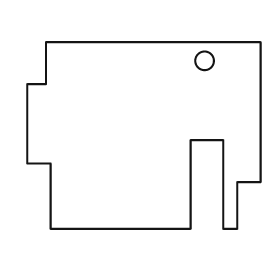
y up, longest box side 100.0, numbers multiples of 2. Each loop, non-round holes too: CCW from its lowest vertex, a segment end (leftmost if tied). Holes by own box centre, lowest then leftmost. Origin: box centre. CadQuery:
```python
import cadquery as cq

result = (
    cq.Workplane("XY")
    .moveTo(-40.0, -40.0)
    .lineTo(20.0, -40.0)
    .lineTo(20.0, -2.0)
    .lineTo(34.0, -2.0)
    .lineTo(34.0, -40.0)
    .lineTo(40.0, -40.0)
    .lineTo(40.0, -20.0)
    .lineTo(50.0, -20.0)
    .lineTo(50.0, 40.0)
    .lineTo(-42.0, 40.0)
    .lineTo(-42.0, 22.0)
    .lineTo(-50.0, 22.0)
    .lineTo(-50.0, -12.0)
    .lineTo(-40.0, -12.0)
    .close()
    .moveTo(26.0, 32.0)
    .circle(4.0)
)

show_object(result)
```